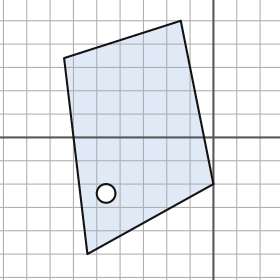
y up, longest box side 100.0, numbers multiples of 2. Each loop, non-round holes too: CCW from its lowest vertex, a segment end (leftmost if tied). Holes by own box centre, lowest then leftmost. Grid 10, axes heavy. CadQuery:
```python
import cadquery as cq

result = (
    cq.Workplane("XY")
    .moveTo(-54.0, -50.0)
    .lineTo(0.0, -20.0)
    .lineTo(-14.0, 50.0)
    .lineTo(-64.0, 34.0)
    .close()
    .moveTo(-46.0, -24.0)
    .circle(4.0)
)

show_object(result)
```